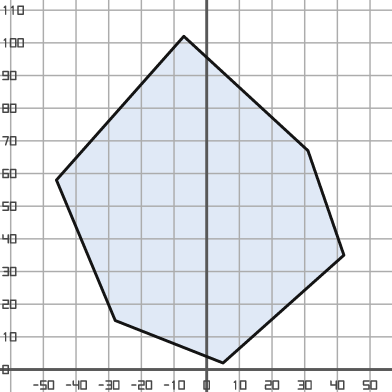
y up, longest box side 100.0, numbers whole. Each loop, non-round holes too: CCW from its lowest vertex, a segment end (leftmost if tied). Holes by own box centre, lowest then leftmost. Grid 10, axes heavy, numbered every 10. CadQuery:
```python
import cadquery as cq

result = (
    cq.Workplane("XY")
    .moveTo(5.0, 2.0)
    .lineTo(42.0, 35.0)
    .lineTo(31.0, 67.0)
    .lineTo(-7.0, 102.0)
    .lineTo(-46.0, 58.0)
    .lineTo(-28.0, 15.0)
    .close()
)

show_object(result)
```